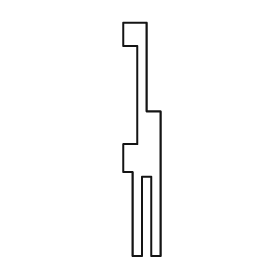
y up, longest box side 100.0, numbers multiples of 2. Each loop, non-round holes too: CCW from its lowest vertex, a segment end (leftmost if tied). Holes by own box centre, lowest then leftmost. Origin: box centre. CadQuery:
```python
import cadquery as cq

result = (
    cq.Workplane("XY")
    .moveTo(-4.0, -50.0)
    .lineTo(0.0, -50.0)
    .lineTo(0.0, -16.0)
    .lineTo(4.0, -16.0)
    .lineTo(4.0, -50.0)
    .lineTo(8.0, -50.0)
    .lineTo(8.0, 12.0)
    .lineTo(2.0, 12.0)
    .lineTo(2.0, 50.0)
    .lineTo(-8.0, 50.0)
    .lineTo(-8.0, 40.0)
    .lineTo(-2.0, 40.0)
    .lineTo(-2.0, -2.0)
    .lineTo(-8.0, -2.0)
    .lineTo(-8.0, -14.0)
    .lineTo(-4.0, -14.0)
    .close()
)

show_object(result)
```